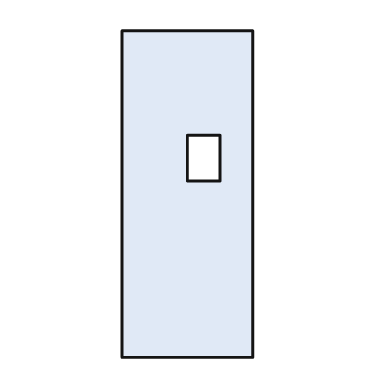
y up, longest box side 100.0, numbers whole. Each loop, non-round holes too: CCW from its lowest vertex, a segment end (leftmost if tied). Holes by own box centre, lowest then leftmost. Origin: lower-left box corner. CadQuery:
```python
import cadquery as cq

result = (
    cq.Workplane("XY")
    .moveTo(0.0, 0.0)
    .lineTo(40.0, 0.0)
    .lineTo(40.0, 100.0)
    .lineTo(0.0, 100.0)
    .close()
    .moveTo(20.0, 54.0)
    .lineTo(30.0, 54.0)
    .lineTo(30.0, 68.0)
    .lineTo(20.0, 68.0)
    .close()
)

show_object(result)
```